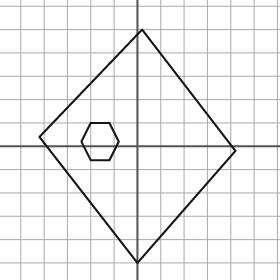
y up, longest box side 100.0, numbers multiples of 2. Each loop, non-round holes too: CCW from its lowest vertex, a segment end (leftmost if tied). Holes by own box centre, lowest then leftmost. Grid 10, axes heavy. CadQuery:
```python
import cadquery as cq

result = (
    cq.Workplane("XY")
    .moveTo(0.0, -50.0)
    .lineTo(42.0, -2.0)
    .lineTo(2.0, 50.0)
    .lineTo(-42.0, 4.0)
    .close()
    .moveTo(-20.0, -6.0)
    .lineTo(-12.0, -6.0)
    .lineTo(-8.0, 2.0)
    .lineTo(-12.0, 10.0)
    .lineTo(-20.0, 10.0)
    .lineTo(-24.0, 2.0)
    .close()
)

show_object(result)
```